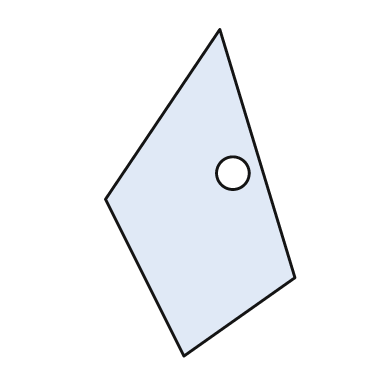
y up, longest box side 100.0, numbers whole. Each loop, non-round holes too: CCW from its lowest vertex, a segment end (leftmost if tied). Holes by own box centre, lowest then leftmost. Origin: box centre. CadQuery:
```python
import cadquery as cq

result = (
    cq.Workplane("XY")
    .moveTo(-5.0, -50.0)
    .lineTo(29.0, -26.0)
    .lineTo(6.0, 50.0)
    .lineTo(-29.0, -2.0)
    .close()
    .moveTo(10.0, 6.0)
    .circle(5.0)
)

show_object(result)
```